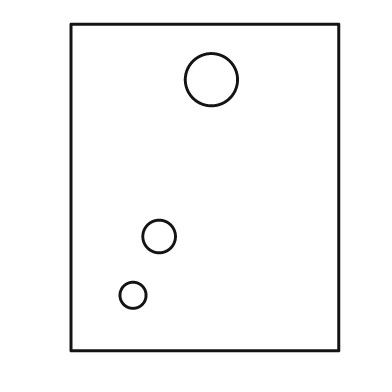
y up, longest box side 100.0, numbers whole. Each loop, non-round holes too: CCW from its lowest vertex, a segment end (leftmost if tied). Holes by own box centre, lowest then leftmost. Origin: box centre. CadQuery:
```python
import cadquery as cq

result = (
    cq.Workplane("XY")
    .moveTo(-41.0, -50.0)
    .lineTo(41.0, -50.0)
    .lineTo(41.0, 50.0)
    .lineTo(-41.0, 50.0)
    .close()
    .moveTo(-22.0, -33.0)
    .circle(4.0)
    .moveTo(-14.0, -15.0)
    .circle(5.0)
    .moveTo(2.0, 33.0)
    .circle(8.0)
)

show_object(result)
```